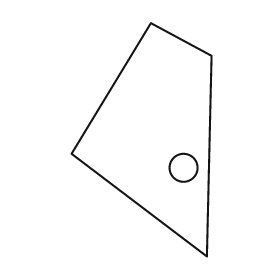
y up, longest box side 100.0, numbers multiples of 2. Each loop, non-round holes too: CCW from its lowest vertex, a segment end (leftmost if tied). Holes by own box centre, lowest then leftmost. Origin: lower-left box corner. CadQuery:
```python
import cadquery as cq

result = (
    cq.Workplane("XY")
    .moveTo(58.0, 0.0)
    .lineTo(60.0, 86.0)
    .lineTo(34.0, 100.0)
    .lineTo(0.0, 44.0)
    .close()
    .moveTo(48.0, 38.0)
    .circle(6.0)
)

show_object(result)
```